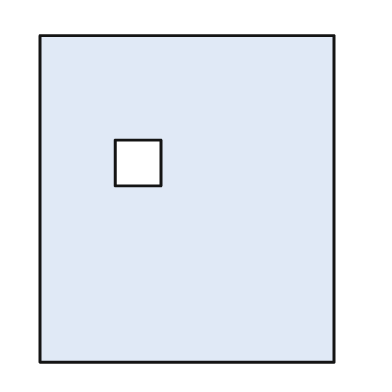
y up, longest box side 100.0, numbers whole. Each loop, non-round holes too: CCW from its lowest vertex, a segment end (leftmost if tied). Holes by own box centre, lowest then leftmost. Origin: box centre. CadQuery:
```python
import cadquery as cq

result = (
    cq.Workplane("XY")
    .moveTo(-45.0, -50.0)
    .lineTo(45.0, -50.0)
    .lineTo(45.0, 50.0)
    .lineTo(-45.0, 50.0)
    .close()
    .moveTo(-22.0, 4.0)
    .lineTo(-8.0, 4.0)
    .lineTo(-8.0, 18.0)
    .lineTo(-22.0, 18.0)
    .close()
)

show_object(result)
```